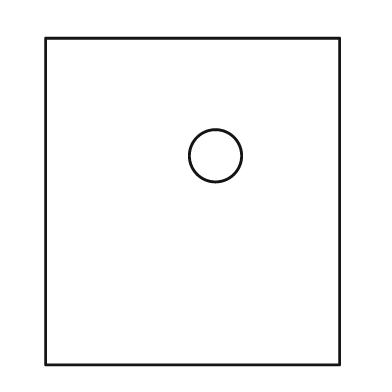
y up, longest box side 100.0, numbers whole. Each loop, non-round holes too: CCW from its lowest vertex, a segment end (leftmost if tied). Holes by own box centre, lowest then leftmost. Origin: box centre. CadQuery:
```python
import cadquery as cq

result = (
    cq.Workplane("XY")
    .moveTo(-45.0, -50.0)
    .lineTo(45.0, -50.0)
    .lineTo(45.0, 50.0)
    .lineTo(-45.0, 50.0)
    .close()
    .moveTo(7.0, 14.0)
    .circle(8.0)
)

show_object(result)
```